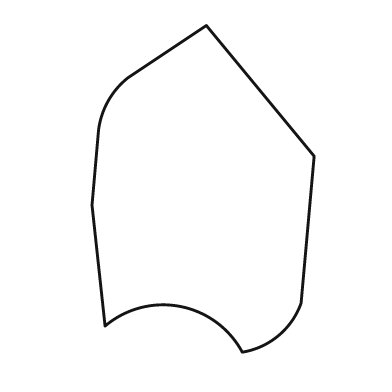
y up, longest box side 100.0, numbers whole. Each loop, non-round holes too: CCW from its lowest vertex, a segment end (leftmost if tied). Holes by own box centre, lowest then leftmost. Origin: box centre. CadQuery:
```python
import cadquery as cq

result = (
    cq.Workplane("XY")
    .moveTo(12.0, -50.0)
    .threePointArc((23.0, -45.0), (30.0, -35.0))
    .lineTo(34.0, 10.0)
    .lineTo(1.0, 50.0)
    .lineTo(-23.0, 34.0)
    .threePointArc((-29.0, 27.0), (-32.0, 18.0))
    .lineTo(-34.0, -5.0)
    .lineTo(-30.0, -42.0)
    .threePointArc((-7.0, -36.0), (12.0, -50.0))
    .close()
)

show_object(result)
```